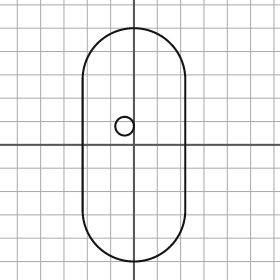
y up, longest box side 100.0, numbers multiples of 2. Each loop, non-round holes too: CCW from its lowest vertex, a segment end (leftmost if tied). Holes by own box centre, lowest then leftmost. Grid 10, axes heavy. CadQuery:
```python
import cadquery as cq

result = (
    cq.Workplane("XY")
    .moveTo(-22.0, -28.0)
    .threePointArc((0.0, -50.0), (22.0, -28.0))
    .lineTo(22.0, 28.0)
    .threePointArc((0.0, 50.0), (-22.0, 28.0))
    .close()
    .moveTo(-4.0, 8.0)
    .circle(4.0)
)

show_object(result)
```